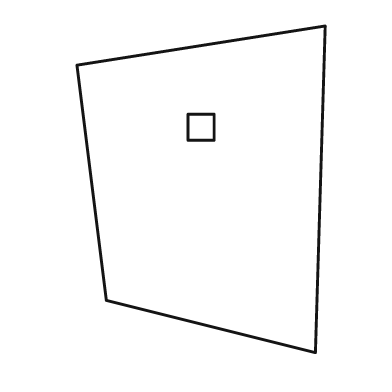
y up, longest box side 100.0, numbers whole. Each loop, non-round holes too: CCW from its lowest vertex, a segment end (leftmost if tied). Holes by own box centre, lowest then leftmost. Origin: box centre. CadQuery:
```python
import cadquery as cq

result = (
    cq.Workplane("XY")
    .moveTo(35.0, -50.0)
    .lineTo(38.0, 50.0)
    .lineTo(-38.0, 38.0)
    .lineTo(-29.0, -34.0)
    .close()
    .moveTo(-4.0, 15.0)
    .lineTo(4.0, 15.0)
    .lineTo(4.0, 23.0)
    .lineTo(-4.0, 23.0)
    .close()
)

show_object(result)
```